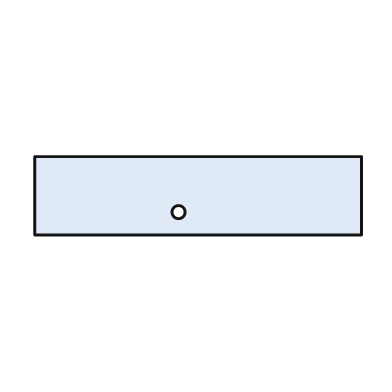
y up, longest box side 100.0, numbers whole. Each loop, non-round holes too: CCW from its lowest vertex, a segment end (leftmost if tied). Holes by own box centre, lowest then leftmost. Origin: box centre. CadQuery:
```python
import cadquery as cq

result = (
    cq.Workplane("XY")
    .moveTo(-50.0, -12.0)
    .lineTo(50.0, -12.0)
    .lineTo(50.0, 12.0)
    .lineTo(-50.0, 12.0)
    .close()
    .moveTo(-6.0, -5.0)
    .circle(2.0)
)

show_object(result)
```